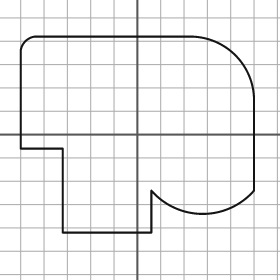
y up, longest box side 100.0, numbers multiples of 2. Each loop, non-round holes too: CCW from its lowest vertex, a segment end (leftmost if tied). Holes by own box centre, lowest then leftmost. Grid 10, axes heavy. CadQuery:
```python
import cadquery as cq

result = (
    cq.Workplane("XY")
    .moveTo(-32.0, -42.0)
    .lineTo(6.0, -42.0)
    .lineTo(6.0, -24.0)
    .threePointArc((28.0, -34.0), (50.0, -24.0))
    .lineTo(50.0, 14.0)
    .threePointArc((42.0, 34.0), (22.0, 42.0))
    .lineTo(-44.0, 42.0)
    .threePointArc((-48.0, 40.0), (-50.0, 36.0))
    .lineTo(-50.0, -6.0)
    .lineTo(-32.0, -6.0)
    .close()
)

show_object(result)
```